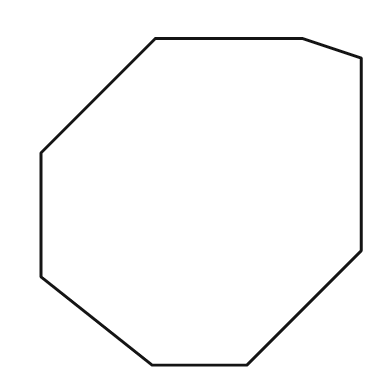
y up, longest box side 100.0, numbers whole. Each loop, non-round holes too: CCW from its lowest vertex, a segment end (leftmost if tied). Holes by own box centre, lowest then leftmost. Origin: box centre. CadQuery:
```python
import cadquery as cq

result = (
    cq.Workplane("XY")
    .moveTo(-15.0, -50.0)
    .lineTo(14.0, -50.0)
    .lineTo(49.0, -15.0)
    .lineTo(49.0, 44.0)
    .lineTo(31.0, 50.0)
    .lineTo(-14.0, 50.0)
    .lineTo(-49.0, 15.0)
    .lineTo(-49.0, -23.0)
    .close()
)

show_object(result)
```